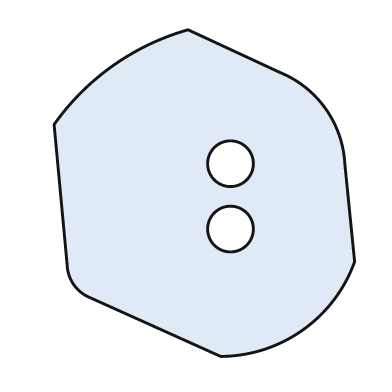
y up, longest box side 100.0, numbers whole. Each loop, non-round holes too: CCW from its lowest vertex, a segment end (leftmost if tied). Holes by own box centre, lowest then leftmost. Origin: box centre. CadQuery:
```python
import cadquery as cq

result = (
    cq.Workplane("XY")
    .moveTo(5.0, -50.0)
    .threePointArc((30.0, -42.0), (46.0, -21.0))
    .lineTo(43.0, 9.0)
    .threePointArc((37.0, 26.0), (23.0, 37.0))
    .lineTo(-5.0, 50.0)
    .threePointArc((-28.0, 39.0), (-46.0, 21.0))
    .lineTo(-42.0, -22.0)
    .threePointArc((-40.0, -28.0), (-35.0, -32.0))
    .close()
    .moveTo(8.0, -11.0)
    .circle(7.0)
    .moveTo(8.0, 9.0)
    .circle(7.0)
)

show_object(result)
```